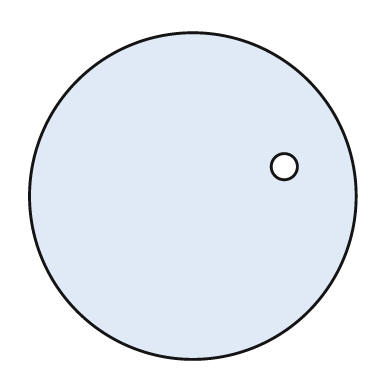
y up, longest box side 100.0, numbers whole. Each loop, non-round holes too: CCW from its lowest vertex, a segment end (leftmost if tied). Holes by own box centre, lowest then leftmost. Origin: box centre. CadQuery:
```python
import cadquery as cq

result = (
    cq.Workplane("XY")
    .moveTo(0.0, 0.0)
    .circle(50.0)
    .moveTo(28.0, 9.0)
    .circle(4.0)
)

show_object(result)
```